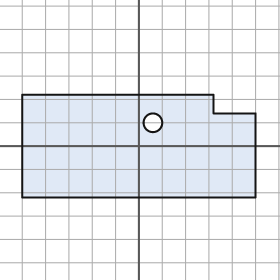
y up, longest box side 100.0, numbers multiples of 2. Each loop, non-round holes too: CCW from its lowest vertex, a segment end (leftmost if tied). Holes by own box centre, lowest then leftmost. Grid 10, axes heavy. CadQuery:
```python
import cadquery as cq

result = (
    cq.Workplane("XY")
    .moveTo(-50.0, -22.0)
    .lineTo(50.0, -22.0)
    .lineTo(50.0, 14.0)
    .lineTo(32.0, 14.0)
    .lineTo(32.0, 22.0)
    .lineTo(-50.0, 22.0)
    .close()
    .moveTo(6.0, 10.0)
    .circle(4.0)
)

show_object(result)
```